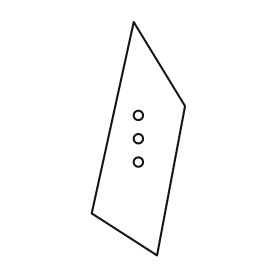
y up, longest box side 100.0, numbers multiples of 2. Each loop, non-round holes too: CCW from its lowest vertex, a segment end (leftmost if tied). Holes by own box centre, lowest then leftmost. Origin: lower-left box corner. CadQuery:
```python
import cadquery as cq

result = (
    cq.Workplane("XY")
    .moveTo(28.0, 0.0)
    .lineTo(40.0, 64.0)
    .lineTo(18.0, 100.0)
    .lineTo(0.0, 18.0)
    .close()
    .moveTo(20.0, 40.0)
    .circle(2.0)
    .moveTo(20.0, 50.0)
    .circle(2.0)
    .moveTo(20.0, 60.0)
    .circle(2.0)
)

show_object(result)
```